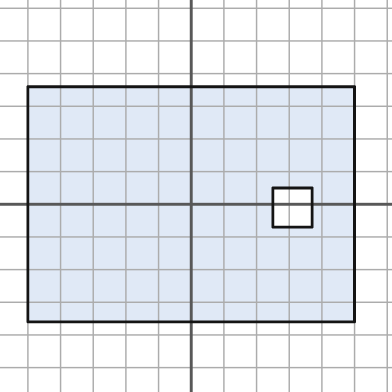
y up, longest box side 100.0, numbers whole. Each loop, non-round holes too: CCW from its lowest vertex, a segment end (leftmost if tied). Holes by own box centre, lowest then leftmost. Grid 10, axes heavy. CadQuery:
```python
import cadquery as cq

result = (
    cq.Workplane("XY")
    .moveTo(-50.0, -36.0)
    .lineTo(50.0, -36.0)
    .lineTo(50.0, 36.0)
    .lineTo(-50.0, 36.0)
    .close()
    .moveTo(25.0, -7.0)
    .lineTo(37.0, -7.0)
    .lineTo(37.0, 5.0)
    .lineTo(25.0, 5.0)
    .close()
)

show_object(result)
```